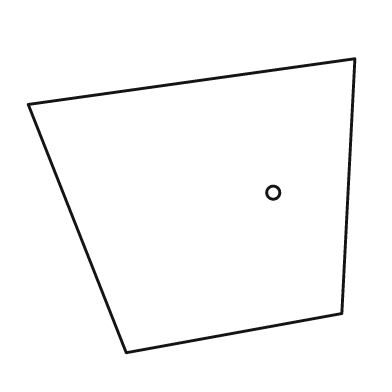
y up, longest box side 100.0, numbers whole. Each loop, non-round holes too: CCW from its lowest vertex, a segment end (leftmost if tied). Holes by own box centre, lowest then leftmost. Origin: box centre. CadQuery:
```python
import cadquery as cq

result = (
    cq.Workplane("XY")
    .moveTo(-20.0, -45.0)
    .lineTo(46.0, -33.0)
    .lineTo(50.0, 45.0)
    .lineTo(-50.0, 31.0)
    .close()
    .moveTo(25.0, 4.0)
    .circle(2.0)
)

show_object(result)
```